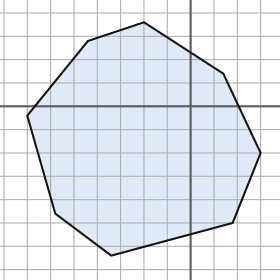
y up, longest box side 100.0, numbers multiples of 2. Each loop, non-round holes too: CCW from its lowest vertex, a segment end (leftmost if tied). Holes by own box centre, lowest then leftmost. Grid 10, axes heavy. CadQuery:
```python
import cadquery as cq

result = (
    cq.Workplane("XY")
    .moveTo(-34.0, -64.0)
    .lineTo(18.0, -50.0)
    .lineTo(30.0, -20.0)
    .lineTo(14.0, 14.0)
    .lineTo(-20.0, 36.0)
    .lineTo(-44.0, 28.0)
    .lineTo(-70.0, -4.0)
    .lineTo(-58.0, -46.0)
    .close()
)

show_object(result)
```